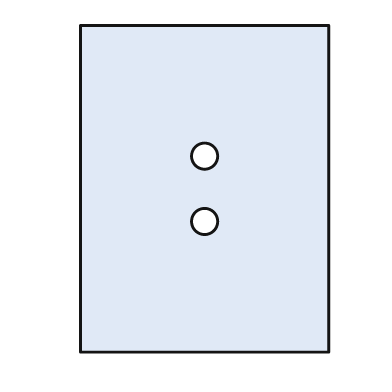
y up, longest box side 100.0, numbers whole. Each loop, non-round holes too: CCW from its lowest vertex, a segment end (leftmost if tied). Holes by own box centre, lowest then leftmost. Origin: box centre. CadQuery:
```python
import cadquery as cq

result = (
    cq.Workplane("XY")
    .moveTo(-38.0, -50.0)
    .lineTo(38.0, -50.0)
    .lineTo(38.0, 50.0)
    .lineTo(-38.0, 50.0)
    .close()
    .moveTo(0.0, -10.0)
    .circle(4.0)
    .moveTo(0.0, 10.0)
    .circle(4.0)
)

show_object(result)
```